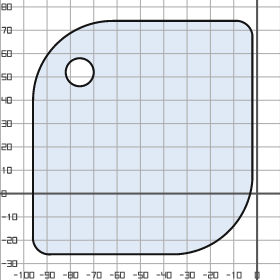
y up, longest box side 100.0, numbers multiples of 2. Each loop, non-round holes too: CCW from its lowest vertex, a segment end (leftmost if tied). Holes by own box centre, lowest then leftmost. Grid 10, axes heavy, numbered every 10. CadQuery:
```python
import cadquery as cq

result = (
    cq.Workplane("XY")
    .moveTo(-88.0, -26.0)
    .lineTo(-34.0, -26.0)
    .threePointArc((-12.0, -16.0), (-2.0, 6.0))
    .lineTo(-2.0, 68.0)
    .threePointArc((-4.0, 72.0), (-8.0, 74.0))
    .lineTo(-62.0, 74.0)
    .threePointArc((-86.0, 64.0), (-96.0, 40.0))
    .lineTo(-96.0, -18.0)
    .threePointArc((-94.0, -24.0), (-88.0, -26.0))
    .close()
    .moveTo(-76.0, 52.0)
    .circle(6.0)
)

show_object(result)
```